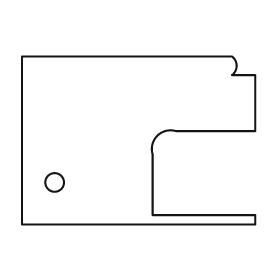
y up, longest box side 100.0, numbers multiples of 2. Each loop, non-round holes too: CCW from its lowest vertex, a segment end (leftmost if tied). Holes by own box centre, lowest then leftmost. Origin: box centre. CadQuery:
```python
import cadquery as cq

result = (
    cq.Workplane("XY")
    .moveTo(-50.0, -36.0)
    .lineTo(50.0, -36.0)
    .lineTo(50.0, -32.0)
    .lineTo(6.0, -32.0)
    .lineTo(6.0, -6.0)
    .threePointArc((8.0, 2.0), (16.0, 4.0))
    .lineTo(50.0, 4.0)
    .lineTo(50.0, 28.0)
    .lineTo(40.0, 28.0)
    .threePointArc((42.0, 32.0), (40.0, 36.0))
    .lineTo(-50.0, 36.0)
    .close()
    .moveTo(-36.0, -18.0)
    .circle(4.0)
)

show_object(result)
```